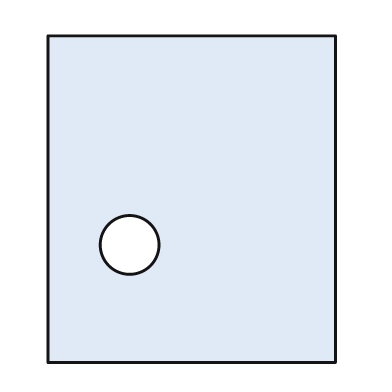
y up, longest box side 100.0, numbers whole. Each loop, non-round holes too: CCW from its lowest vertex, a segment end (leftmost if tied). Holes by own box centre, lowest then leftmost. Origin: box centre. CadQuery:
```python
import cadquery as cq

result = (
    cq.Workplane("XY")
    .moveTo(-44.0, -50.0)
    .lineTo(44.0, -50.0)
    .lineTo(44.0, 50.0)
    .lineTo(-44.0, 50.0)
    .close()
    .moveTo(-19.0, -14.0)
    .circle(9.0)
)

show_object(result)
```